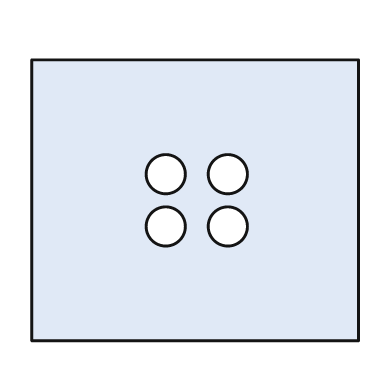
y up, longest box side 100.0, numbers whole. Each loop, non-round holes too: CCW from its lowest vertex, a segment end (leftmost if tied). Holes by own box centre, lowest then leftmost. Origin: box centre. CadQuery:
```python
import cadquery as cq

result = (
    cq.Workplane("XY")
    .moveTo(-50.0, -43.0)
    .lineTo(50.0, -43.0)
    .lineTo(50.0, 43.0)
    .lineTo(-50.0, 43.0)
    .close()
    .moveTo(-9.0, -8.0)
    .circle(6.0)
    .moveTo(10.0, -8.0)
    .circle(6.0)
    .moveTo(-9.0, 8.0)
    .circle(6.0)
    .moveTo(10.0, 8.0)
    .circle(6.0)
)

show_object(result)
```